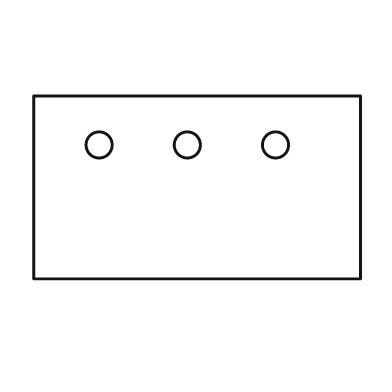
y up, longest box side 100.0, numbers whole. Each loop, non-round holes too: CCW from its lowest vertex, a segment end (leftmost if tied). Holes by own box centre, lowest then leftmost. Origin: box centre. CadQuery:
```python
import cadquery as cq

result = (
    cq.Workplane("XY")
    .moveTo(-50.0, -28.0)
    .lineTo(50.0, -28.0)
    .lineTo(50.0, 28.0)
    .lineTo(-50.0, 28.0)
    .close()
    .moveTo(-30.0, 13.0)
    .circle(4.0)
    .moveTo(-3.0, 13.0)
    .circle(4.0)
    .moveTo(24.0, 13.0)
    .circle(4.0)
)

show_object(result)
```